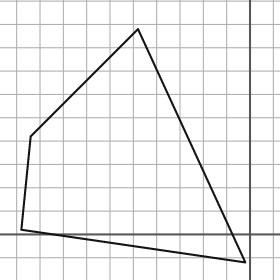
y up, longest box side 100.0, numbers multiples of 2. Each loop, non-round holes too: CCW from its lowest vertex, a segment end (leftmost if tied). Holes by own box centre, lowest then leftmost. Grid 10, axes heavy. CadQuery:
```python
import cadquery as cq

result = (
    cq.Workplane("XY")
    .moveTo(-2.0, -12.0)
    .lineTo(-48.0, 88.0)
    .lineTo(-94.0, 42.0)
    .lineTo(-98.0, 2.0)
    .close()
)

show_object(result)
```